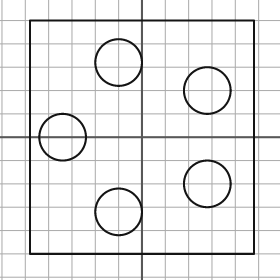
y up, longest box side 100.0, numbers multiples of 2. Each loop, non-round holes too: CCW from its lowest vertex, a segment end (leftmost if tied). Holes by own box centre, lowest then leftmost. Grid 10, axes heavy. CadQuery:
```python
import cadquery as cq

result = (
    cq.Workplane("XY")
    .moveTo(-48.0, -50.0)
    .lineTo(48.0, -50.0)
    .lineTo(48.0, 50.0)
    .lineTo(-48.0, 50.0)
    .close()
    .moveTo(-10.0, -32.0)
    .circle(10.0)
    .moveTo(28.0, -20.0)
    .circle(10.0)
    .moveTo(-34.0, 0.0)
    .circle(10.0)
    .moveTo(28.0, 20.0)
    .circle(10.0)
    .moveTo(-10.0, 32.0)
    .circle(10.0)
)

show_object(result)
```